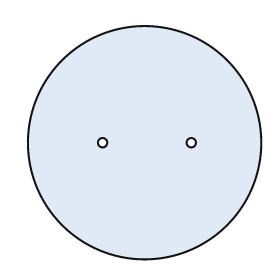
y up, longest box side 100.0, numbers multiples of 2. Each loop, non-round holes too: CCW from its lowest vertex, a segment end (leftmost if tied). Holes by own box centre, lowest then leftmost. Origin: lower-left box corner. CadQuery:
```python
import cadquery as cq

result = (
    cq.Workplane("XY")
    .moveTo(50.0, 50.0)
    .circle(50.0)
    .moveTo(32.0, 50.0)
    .circle(2.0)
    .moveTo(70.0, 50.0)
    .circle(2.0)
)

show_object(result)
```